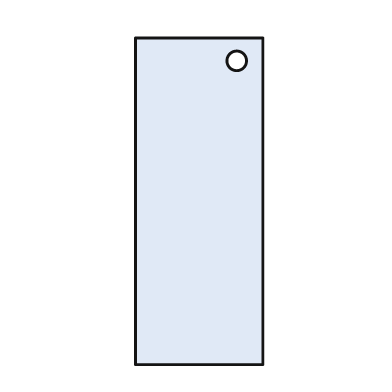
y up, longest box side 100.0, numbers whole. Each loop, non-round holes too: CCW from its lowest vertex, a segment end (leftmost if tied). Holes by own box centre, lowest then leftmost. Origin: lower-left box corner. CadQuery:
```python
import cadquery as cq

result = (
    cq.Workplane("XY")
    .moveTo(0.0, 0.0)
    .lineTo(39.0, 0.0)
    .lineTo(39.0, 100.0)
    .lineTo(0.0, 100.0)
    .close()
    .moveTo(31.0, 93.0)
    .circle(3.0)
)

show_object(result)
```